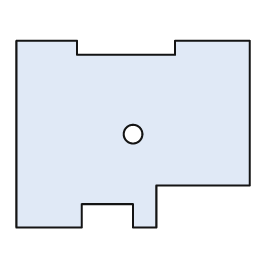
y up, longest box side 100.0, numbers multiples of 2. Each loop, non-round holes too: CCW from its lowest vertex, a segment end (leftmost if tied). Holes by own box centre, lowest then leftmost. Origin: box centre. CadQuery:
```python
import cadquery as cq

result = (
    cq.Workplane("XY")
    .moveTo(-50.0, -40.0)
    .lineTo(-22.0, -40.0)
    .lineTo(-22.0, -30.0)
    .lineTo(0.0, -30.0)
    .lineTo(0.0, -40.0)
    .lineTo(10.0, -40.0)
    .lineTo(10.0, -22.0)
    .lineTo(50.0, -22.0)
    .lineTo(50.0, 40.0)
    .lineTo(18.0, 40.0)
    .lineTo(18.0, 34.0)
    .lineTo(-24.0, 34.0)
    .lineTo(-24.0, 40.0)
    .lineTo(-50.0, 40.0)
    .close()
    .moveTo(0.0, 0.0)
    .circle(4.0)
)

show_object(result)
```